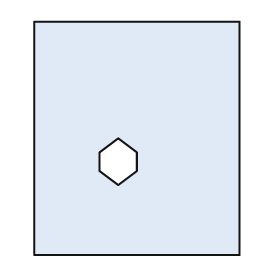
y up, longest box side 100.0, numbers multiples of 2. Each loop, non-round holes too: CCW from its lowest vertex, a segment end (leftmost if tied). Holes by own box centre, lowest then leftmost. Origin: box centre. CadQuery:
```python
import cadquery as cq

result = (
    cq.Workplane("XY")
    .moveTo(-44.0, -50.0)
    .lineTo(44.0, -50.0)
    .lineTo(44.0, 50.0)
    .lineTo(-44.0, 50.0)
    .close()
    .moveTo(-8.0, -20.0)
    .lineTo(0.0, -14.0)
    .lineTo(0.0, -6.0)
    .lineTo(-8.0, 0.0)
    .lineTo(-16.0, -6.0)
    .lineTo(-16.0, -14.0)
    .close()
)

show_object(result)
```